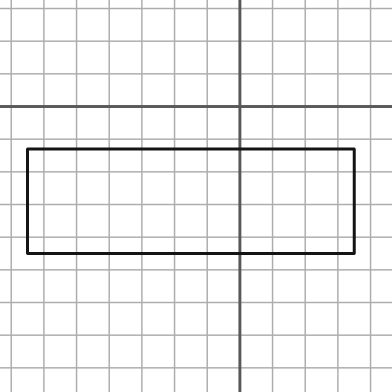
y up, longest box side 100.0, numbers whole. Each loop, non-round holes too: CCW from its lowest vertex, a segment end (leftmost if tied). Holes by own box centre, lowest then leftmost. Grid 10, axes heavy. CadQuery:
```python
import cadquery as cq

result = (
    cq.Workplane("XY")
    .moveTo(-65.0, -45.0)
    .lineTo(35.0, -45.0)
    .lineTo(35.0, -13.0)
    .lineTo(-65.0, -13.0)
    .close()
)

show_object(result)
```